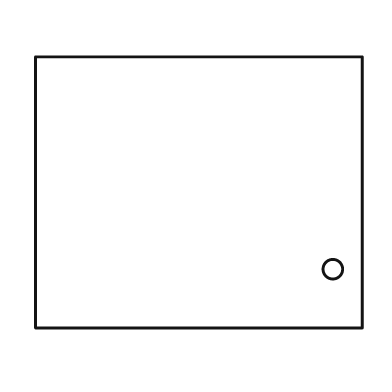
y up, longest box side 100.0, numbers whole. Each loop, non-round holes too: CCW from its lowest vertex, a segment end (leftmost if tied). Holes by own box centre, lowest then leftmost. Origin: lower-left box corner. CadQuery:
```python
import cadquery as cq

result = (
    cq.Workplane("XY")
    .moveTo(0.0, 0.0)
    .lineTo(100.0, 0.0)
    .lineTo(100.0, 83.0)
    .lineTo(0.0, 83.0)
    .close()
    .moveTo(91.0, 18.0)
    .circle(3.0)
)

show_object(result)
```